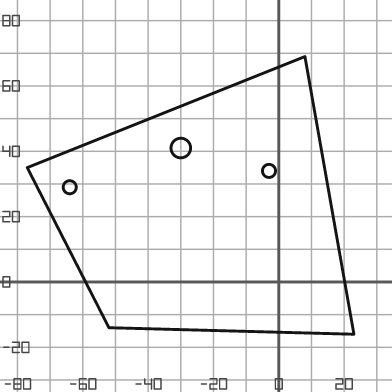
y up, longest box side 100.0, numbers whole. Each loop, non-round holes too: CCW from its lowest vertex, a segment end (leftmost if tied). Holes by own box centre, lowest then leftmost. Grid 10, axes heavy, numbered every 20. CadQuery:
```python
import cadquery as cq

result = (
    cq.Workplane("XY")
    .moveTo(23.0, -16.0)
    .lineTo(8.0, 69.0)
    .lineTo(-77.0, 35.0)
    .lineTo(-52.0, -14.0)
    .close()
    .moveTo(-64.0, 29.0)
    .circle(2.0)
    .moveTo(-3.0, 34.0)
    .circle(2.0)
    .moveTo(-30.0, 41.0)
    .circle(3.0)
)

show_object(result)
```